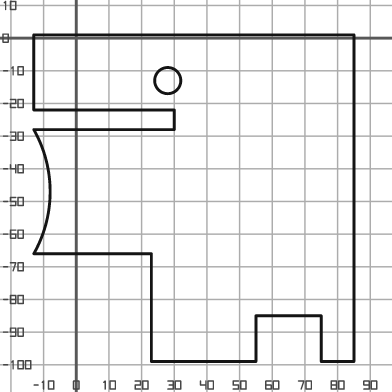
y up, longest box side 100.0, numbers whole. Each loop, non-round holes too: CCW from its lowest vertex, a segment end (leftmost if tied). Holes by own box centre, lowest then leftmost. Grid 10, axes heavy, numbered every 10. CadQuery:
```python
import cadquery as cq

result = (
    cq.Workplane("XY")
    .moveTo(23.0, -99.0)
    .lineTo(55.0, -99.0)
    .lineTo(55.0, -85.0)
    .lineTo(75.0, -85.0)
    .lineTo(75.0, -99.0)
    .lineTo(85.0, -99.0)
    .lineTo(85.0, 1.0)
    .lineTo(-13.0, 1.0)
    .lineTo(-13.0, -22.0)
    .lineTo(30.0, -22.0)
    .lineTo(30.0, -28.0)
    .lineTo(-13.0, -28.0)
    .threePointArc((-8.0, -47.0), (-13.0, -66.0))
    .lineTo(23.0, -66.0)
    .close()
    .moveTo(28.0, -13.0)
    .circle(4.0)
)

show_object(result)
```